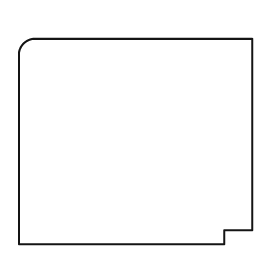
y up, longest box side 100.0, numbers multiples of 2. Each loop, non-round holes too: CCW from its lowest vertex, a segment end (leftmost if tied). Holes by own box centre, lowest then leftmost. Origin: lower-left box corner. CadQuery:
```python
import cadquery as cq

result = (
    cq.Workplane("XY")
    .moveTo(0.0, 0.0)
    .lineTo(88.0, 0.0)
    .lineTo(88.0, 6.0)
    .lineTo(100.0, 6.0)
    .lineTo(100.0, 88.0)
    .lineTo(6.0, 88.0)
    .threePointArc((2.0, 86.0), (0.0, 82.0))
    .close()
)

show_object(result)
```